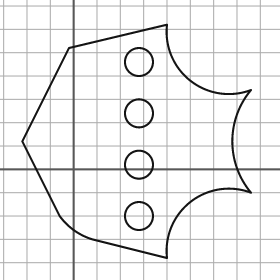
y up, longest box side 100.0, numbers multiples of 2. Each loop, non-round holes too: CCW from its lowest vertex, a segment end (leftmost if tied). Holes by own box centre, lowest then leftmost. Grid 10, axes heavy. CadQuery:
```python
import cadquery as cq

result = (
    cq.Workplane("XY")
    .moveTo(40.0, -38.0)
    .threePointArc((50.0, -14.0), (76.0, -10.0))
    .threePointArc((68.0, 12.0), (76.0, 34.0))
    .threePointArc((50.0, 38.0), (40.0, 62.0))
    .lineTo(-2.0, 52.0)
    .lineTo(-22.0, 12.0)
    .lineTo(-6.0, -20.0)
    .threePointArc((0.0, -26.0), (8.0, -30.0))
    .close()
    .moveTo(28.0, -20.0)
    .circle(6.0)
    .moveTo(28.0, 2.0)
    .circle(6.0)
    .moveTo(28.0, 24.0)
    .circle(6.0)
    .moveTo(28.0, 46.0)
    .circle(6.0)
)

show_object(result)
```